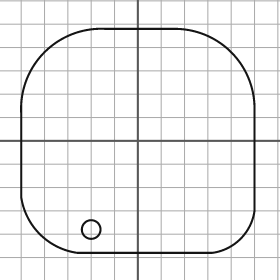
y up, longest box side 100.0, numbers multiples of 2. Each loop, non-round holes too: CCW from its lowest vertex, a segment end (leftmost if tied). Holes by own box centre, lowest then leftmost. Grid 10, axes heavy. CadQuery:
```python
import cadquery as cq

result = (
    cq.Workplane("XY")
    .moveTo(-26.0, -48.0)
    .lineTo(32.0, -48.0)
    .threePointArc((44.0, -42.0), (50.0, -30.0))
    .lineTo(50.0, 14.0)
    .threePointArc((40.0, 38.0), (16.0, 48.0))
    .lineTo(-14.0, 48.0)
    .threePointArc((-40.0, 38.0), (-50.0, 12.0))
    .lineTo(-50.0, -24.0)
    .threePointArc((-42.0, -40.0), (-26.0, -48.0))
    .close()
    .moveTo(-20.0, -38.0)
    .circle(4.0)
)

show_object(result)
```